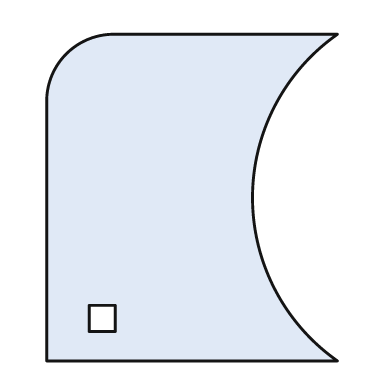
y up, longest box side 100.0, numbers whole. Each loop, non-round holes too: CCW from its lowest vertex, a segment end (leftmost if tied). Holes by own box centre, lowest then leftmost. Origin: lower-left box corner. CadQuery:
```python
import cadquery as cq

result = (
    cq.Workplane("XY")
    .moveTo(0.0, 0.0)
    .lineTo(89.0, 0.0)
    .threePointArc((63.0, 50.0), (89.0, 100.0))
    .lineTo(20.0, 100.0)
    .threePointArc((6.0, 94.0), (0.0, 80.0))
    .close()
    .moveTo(13.0, 9.0)
    .lineTo(21.0, 9.0)
    .lineTo(21.0, 17.0)
    .lineTo(13.0, 17.0)
    .close()
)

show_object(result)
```